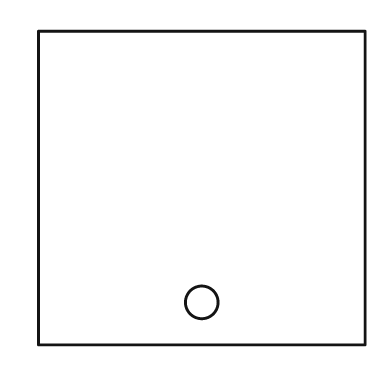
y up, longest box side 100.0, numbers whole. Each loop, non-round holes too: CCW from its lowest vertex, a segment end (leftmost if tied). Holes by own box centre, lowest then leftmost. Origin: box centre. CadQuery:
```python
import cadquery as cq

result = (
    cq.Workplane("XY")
    .moveTo(-50.0, -48.0)
    .lineTo(50.0, -48.0)
    .lineTo(50.0, 48.0)
    .lineTo(-50.0, 48.0)
    .close()
    .moveTo(0.0, -35.0)
    .circle(5.0)
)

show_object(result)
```